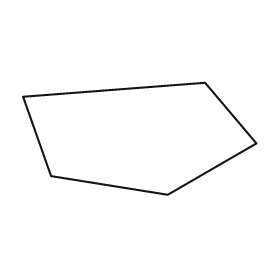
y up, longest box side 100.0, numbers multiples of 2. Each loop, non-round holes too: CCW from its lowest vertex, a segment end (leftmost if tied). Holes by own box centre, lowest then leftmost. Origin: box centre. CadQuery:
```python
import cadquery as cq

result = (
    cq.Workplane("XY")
    .moveTo(12.0, -24.0)
    .lineTo(50.0, -2.0)
    .lineTo(28.0, 24.0)
    .lineTo(-50.0, 18.0)
    .lineTo(-38.0, -16.0)
    .close()
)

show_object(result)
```